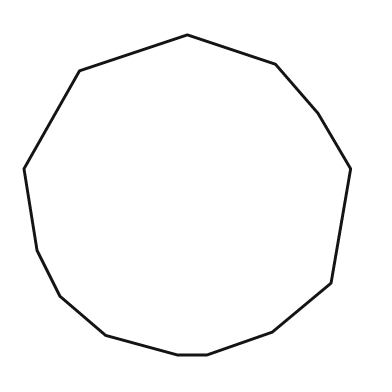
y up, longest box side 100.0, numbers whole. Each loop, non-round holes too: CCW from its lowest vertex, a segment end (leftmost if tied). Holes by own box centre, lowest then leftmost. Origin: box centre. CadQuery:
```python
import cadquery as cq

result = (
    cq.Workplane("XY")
    .moveTo(-3.0, -49.0)
    .lineTo(6.0, -49.0)
    .lineTo(26.0, -42.0)
    .lineTo(44.0, -27.0)
    .lineTo(50.0, 8.0)
    .lineTo(40.0, 25.0)
    .lineTo(27.0, 40.0)
    .lineTo(0.0, 49.0)
    .lineTo(-33.0, 38.0)
    .lineTo(-50.0, 8.0)
    .lineTo(-46.0, -17.0)
    .lineTo(-39.0, -31.0)
    .lineTo(-25.0, -43.0)
    .close()
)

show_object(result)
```